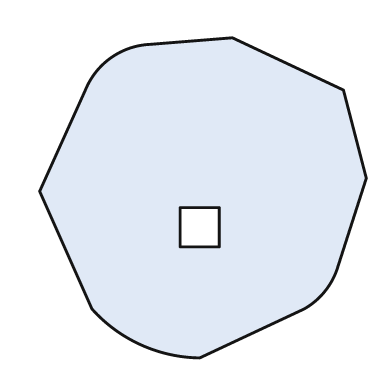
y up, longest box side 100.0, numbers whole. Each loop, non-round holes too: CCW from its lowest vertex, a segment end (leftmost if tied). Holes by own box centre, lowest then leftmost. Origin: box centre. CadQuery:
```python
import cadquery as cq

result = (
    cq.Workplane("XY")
    .moveTo(-1.0, -49.0)
    .lineTo(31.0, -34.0)
    .threePointArc((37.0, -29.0), (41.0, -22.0))
    .lineTo(50.0, 6.0)
    .lineTo(43.0, 33.0)
    .lineTo(9.0, 49.0)
    .lineTo(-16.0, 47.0)
    .threePointArc((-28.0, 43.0), (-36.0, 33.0))
    .lineTo(-50.0, 2.0)
    .lineTo(-34.0, -34.0)
    .threePointArc((-19.0, -45.0), (-1.0, -49.0))
    .close()
    .moveTo(-7.0, -15.0)
    .lineTo(5.0, -15.0)
    .lineTo(5.0, -3.0)
    .lineTo(-7.0, -3.0)
    .close()
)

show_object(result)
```